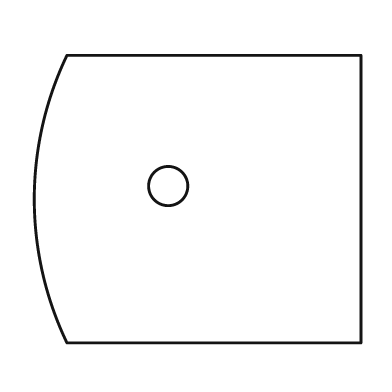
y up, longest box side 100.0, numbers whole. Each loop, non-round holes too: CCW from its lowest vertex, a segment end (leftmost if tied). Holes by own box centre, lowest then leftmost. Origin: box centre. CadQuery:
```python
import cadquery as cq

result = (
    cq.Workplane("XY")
    .moveTo(-40.0, -44.0)
    .lineTo(50.0, -44.0)
    .lineTo(50.0, 44.0)
    .lineTo(-40.0, 44.0)
    .threePointArc((-50.0, 0.0), (-40.0, -44.0))
    .close()
    .moveTo(-9.0, 4.0)
    .circle(6.0)
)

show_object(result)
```